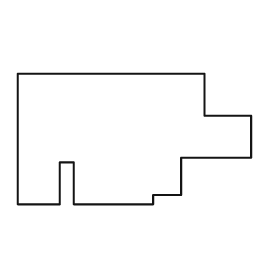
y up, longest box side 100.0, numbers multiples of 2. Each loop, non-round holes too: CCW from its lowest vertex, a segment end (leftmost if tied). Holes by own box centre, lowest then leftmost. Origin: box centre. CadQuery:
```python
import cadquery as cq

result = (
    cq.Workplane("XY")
    .moveTo(-50.0, -28.0)
    .lineTo(-32.0, -28.0)
    .lineTo(-32.0, -10.0)
    .lineTo(-26.0, -10.0)
    .lineTo(-26.0, -28.0)
    .lineTo(8.0, -28.0)
    .lineTo(8.0, -24.0)
    .lineTo(20.0, -24.0)
    .lineTo(20.0, -8.0)
    .lineTo(50.0, -8.0)
    .lineTo(50.0, 10.0)
    .lineTo(30.0, 10.0)
    .lineTo(30.0, 28.0)
    .lineTo(-50.0, 28.0)
    .close()
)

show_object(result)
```